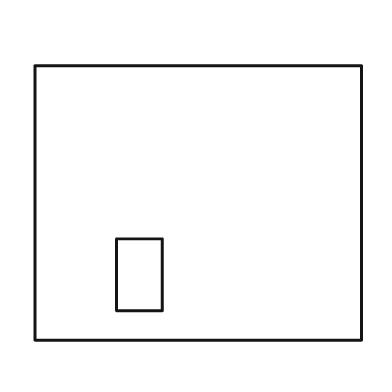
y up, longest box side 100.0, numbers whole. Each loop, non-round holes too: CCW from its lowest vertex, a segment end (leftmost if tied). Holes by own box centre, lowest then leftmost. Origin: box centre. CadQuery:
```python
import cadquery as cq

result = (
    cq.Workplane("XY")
    .moveTo(-50.0, -42.0)
    .lineTo(50.0, -42.0)
    .lineTo(50.0, 42.0)
    .lineTo(-50.0, 42.0)
    .close()
    .moveTo(-25.0, -33.0)
    .lineTo(-11.0, -33.0)
    .lineTo(-11.0, -11.0)
    .lineTo(-25.0, -11.0)
    .close()
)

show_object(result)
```